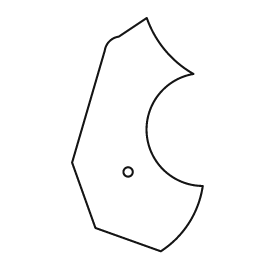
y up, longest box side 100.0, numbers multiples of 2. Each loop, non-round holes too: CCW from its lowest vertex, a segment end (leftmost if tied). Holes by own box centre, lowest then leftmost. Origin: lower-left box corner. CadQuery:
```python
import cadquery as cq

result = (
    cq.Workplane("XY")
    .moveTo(38.0, 0.0)
    .threePointArc((50.0, 12.0), (56.0, 28.0))
    .threePointArc((32.0, 50.0), (52.0, 76.0))
    .threePointArc((40.0, 86.0), (32.0, 100.0))
    .lineTo(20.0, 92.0)
    .threePointArc((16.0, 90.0), (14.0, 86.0))
    .lineTo(0.0, 38.0)
    .lineTo(10.0, 10.0)
    .close()
    .moveTo(24.0, 34.0)
    .circle(2.0)
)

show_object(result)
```